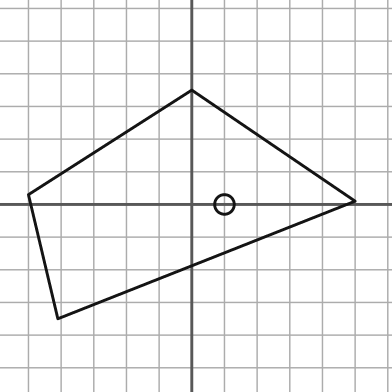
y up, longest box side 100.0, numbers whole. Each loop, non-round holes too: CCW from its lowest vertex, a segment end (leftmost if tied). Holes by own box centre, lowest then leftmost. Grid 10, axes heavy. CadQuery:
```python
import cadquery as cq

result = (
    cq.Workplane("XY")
    .moveTo(-41.0, -35.0)
    .lineTo(50.0, 1.0)
    .lineTo(0.0, 35.0)
    .lineTo(-50.0, 3.0)
    .close()
    .moveTo(10.0, 0.0)
    .circle(3.0)
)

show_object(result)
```